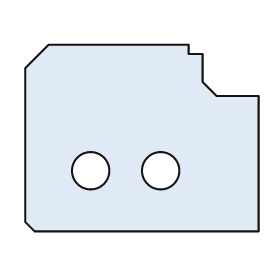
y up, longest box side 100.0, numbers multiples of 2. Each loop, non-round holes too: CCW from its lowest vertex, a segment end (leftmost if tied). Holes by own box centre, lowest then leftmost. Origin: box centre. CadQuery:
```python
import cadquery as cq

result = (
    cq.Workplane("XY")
    .moveTo(-46.0, -40.0)
    .lineTo(50.0, -40.0)
    .lineTo(50.0, 18.0)
    .lineTo(32.0, 18.0)
    .lineTo(26.0, 24.0)
    .lineTo(26.0, 36.0)
    .lineTo(20.0, 36.0)
    .lineTo(20.0, 40.0)
    .lineTo(-40.0, 40.0)
    .lineTo(-50.0, 30.0)
    .lineTo(-50.0, -36.0)
    .close()
    .moveTo(-22.0, -14.0)
    .circle(8.0)
    .moveTo(8.0, -14.0)
    .circle(8.0)
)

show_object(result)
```